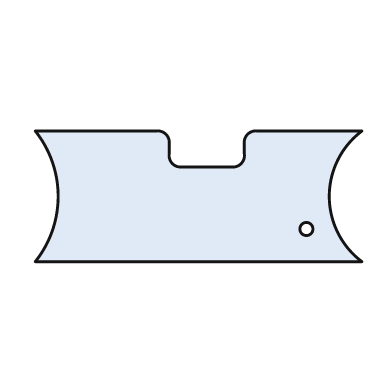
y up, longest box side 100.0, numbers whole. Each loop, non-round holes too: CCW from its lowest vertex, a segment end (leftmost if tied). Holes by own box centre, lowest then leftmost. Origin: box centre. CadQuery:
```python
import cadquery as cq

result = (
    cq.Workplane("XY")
    .moveTo(-50.0, -20.0)
    .lineTo(50.0, -20.0)
    .threePointArc((40.0, 0.0), (50.0, 20.0))
    .lineTo(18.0, 20.0)
    .threePointArc((15.0, 19.0), (14.0, 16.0))
    .lineTo(14.0, 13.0)
    .threePointArc((13.0, 10.0), (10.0, 9.0))
    .lineTo(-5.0, 9.0)
    .threePointArc((-8.0, 10.0), (-9.0, 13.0))
    .lineTo(-9.0, 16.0)
    .threePointArc((-10.0, 19.0), (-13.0, 20.0))
    .lineTo(-50.0, 20.0)
    .threePointArc((-43.0, 0.0), (-50.0, -20.0))
    .close()
    .moveTo(33.0, -10.0)
    .circle(2.0)
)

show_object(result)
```